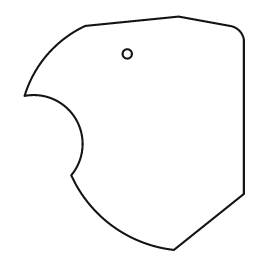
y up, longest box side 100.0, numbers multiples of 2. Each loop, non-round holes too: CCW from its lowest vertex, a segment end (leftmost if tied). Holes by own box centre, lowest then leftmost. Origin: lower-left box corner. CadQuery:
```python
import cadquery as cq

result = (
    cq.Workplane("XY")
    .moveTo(64.0, 0.0)
    .lineTo(94.0, 24.0)
    .lineTo(94.0, 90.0)
    .threePointArc((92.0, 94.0), (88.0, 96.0))
    .lineTo(66.0, 100.0)
    .lineTo(26.0, 96.0)
    .threePointArc((10.0, 84.0), (0.0, 66.0))
    .threePointArc((22.0, 56.0), (20.0, 32.0))
    .threePointArc((38.0, 10.0), (64.0, 0.0))
    .close()
    .moveTo(44.0, 84.0)
    .circle(2.0)
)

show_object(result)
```